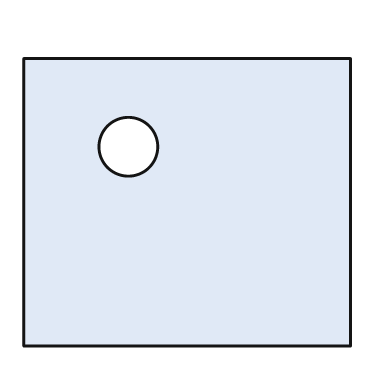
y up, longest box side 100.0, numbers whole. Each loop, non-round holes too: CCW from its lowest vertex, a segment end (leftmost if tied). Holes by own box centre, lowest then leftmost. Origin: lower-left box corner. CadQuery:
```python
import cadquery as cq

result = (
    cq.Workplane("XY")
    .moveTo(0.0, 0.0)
    .lineTo(100.0, 0.0)
    .lineTo(100.0, 88.0)
    .lineTo(0.0, 88.0)
    .close()
    .moveTo(32.0, 61.0)
    .circle(9.0)
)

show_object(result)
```